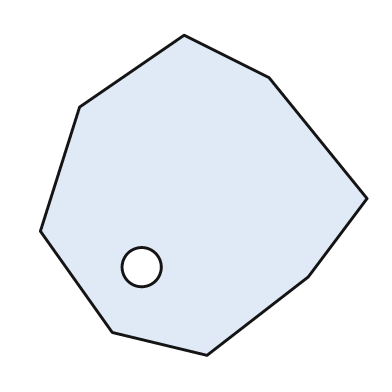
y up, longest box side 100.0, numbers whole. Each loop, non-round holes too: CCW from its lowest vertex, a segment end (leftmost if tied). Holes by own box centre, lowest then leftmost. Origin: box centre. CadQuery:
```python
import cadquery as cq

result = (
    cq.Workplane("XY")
    .moveTo(1.0, -49.0)
    .lineTo(32.0, -25.0)
    .lineTo(50.0, -1.0)
    .lineTo(20.0, 36.0)
    .lineTo(-6.0, 49.0)
    .lineTo(-38.0, 27.0)
    .lineTo(-50.0, -11.0)
    .lineTo(-28.0, -42.0)
    .close()
    .moveTo(-19.0, -22.0)
    .circle(6.0)
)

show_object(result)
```